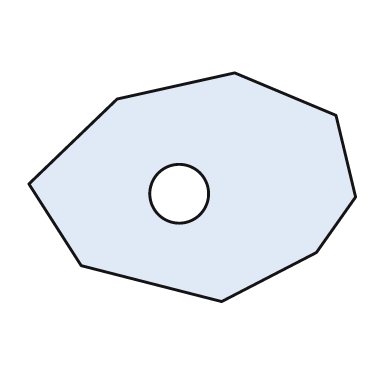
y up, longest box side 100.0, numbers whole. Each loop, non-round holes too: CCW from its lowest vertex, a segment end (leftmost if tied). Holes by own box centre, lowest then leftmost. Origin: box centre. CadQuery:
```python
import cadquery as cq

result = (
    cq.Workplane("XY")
    .moveTo(9.0, -35.0)
    .lineTo(38.0, -20.0)
    .lineTo(50.0, -3.0)
    .lineTo(44.0, 22.0)
    .lineTo(13.0, 35.0)
    .lineTo(-23.0, 27.0)
    .lineTo(-50.0, 1.0)
    .lineTo(-34.0, -24.0)
    .close()
    .moveTo(-4.0, -2.0)
    .circle(9.0)
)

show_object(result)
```